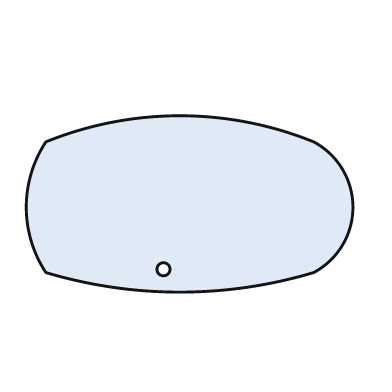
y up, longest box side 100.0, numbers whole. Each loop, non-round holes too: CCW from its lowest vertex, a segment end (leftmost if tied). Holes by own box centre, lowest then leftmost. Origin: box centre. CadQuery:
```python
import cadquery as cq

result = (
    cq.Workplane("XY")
    .moveTo(-44.0, -21.0)
    .threePointArc((-3.0, -27.0), (38.0, -21.0))
    .threePointArc((50.0, -1.0), (38.0, 19.0))
    .threePointArc((-3.0, 27.0), (-44.0, 19.0))
    .threePointArc((-50.0, -1.0), (-44.0, -21.0))
    .close()
    .moveTo(-8.0, -20.0)
    .circle(2.0)
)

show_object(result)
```